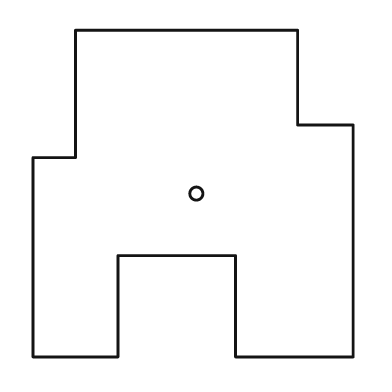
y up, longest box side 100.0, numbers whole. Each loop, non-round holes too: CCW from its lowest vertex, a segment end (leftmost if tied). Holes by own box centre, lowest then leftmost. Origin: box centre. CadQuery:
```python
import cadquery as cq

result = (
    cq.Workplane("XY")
    .moveTo(-49.0, -50.0)
    .lineTo(-23.0, -50.0)
    .lineTo(-23.0, -19.0)
    .lineTo(13.0, -19.0)
    .lineTo(13.0, -50.0)
    .lineTo(49.0, -50.0)
    .lineTo(49.0, 21.0)
    .lineTo(32.0, 21.0)
    .lineTo(32.0, 50.0)
    .lineTo(-36.0, 50.0)
    .lineTo(-36.0, 11.0)
    .lineTo(-49.0, 11.0)
    .close()
    .moveTo(1.0, 0.0)
    .circle(2.0)
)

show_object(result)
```